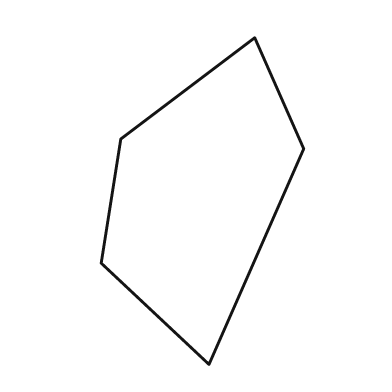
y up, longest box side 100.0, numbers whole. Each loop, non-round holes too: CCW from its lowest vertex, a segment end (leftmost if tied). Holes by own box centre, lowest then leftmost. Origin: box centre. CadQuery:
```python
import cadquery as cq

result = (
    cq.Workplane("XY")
    .moveTo(2.0, -50.0)
    .lineTo(31.0, 16.0)
    .lineTo(16.0, 50.0)
    .lineTo(-25.0, 19.0)
    .lineTo(-31.0, -19.0)
    .close()
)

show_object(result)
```